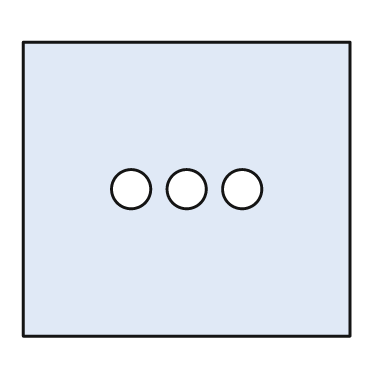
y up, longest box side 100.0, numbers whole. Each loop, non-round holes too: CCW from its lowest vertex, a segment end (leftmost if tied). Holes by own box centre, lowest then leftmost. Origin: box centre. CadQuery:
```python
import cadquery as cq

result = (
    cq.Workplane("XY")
    .moveTo(-50.0, -45.0)
    .lineTo(50.0, -45.0)
    .lineTo(50.0, 45.0)
    .lineTo(-50.0, 45.0)
    .close()
    .moveTo(-17.0, 0.0)
    .circle(6.0)
    .moveTo(0.0, 0.0)
    .circle(6.0)
    .moveTo(17.0, 0.0)
    .circle(6.0)
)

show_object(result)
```